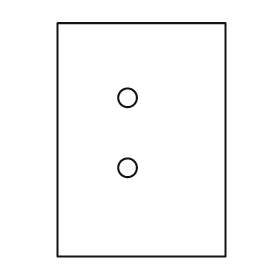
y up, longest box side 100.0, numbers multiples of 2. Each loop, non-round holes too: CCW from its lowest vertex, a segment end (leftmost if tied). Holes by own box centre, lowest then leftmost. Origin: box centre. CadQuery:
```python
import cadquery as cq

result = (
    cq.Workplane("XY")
    .moveTo(-36.0, -50.0)
    .lineTo(36.0, -50.0)
    .lineTo(36.0, 50.0)
    .lineTo(-36.0, 50.0)
    .close()
    .moveTo(-6.0, -12.0)
    .circle(4.0)
    .moveTo(-6.0, 18.0)
    .circle(4.0)
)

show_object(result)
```